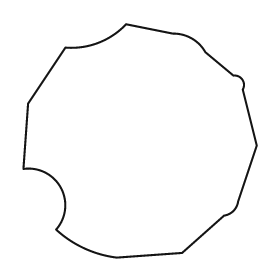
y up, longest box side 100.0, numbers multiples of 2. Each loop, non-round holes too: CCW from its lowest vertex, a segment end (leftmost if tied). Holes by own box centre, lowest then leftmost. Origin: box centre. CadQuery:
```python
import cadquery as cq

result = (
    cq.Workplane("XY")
    .moveTo(-10.0, -50.0)
    .lineTo(18.0, -48.0)
    .lineTo(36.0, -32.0)
    .threePointArc((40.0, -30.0), (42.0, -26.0))
    .lineTo(50.0, -2.0)
    .lineTo(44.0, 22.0)
    .threePointArc((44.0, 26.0), (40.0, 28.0))
    .lineTo(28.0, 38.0)
    .threePointArc((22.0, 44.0), (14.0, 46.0))
    .lineTo(-6.0, 50.0)
    .threePointArc((-18.0, 42.0), (-32.0, 40.0))
    .lineTo(-48.0, 16.0)
    .lineTo(-50.0, -12.0)
    .threePointArc((-34.0, -20.0), (-36.0, -38.0))
    .threePointArc((-24.0, -46.0), (-10.0, -50.0))
    .close()
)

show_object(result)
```